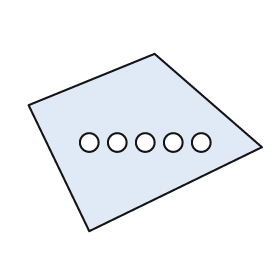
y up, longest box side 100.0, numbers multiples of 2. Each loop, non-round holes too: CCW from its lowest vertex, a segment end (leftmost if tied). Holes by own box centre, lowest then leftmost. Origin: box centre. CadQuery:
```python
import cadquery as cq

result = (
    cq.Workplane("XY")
    .moveTo(-24.0, -38.0)
    .lineTo(50.0, -2.0)
    .lineTo(4.0, 38.0)
    .lineTo(-50.0, 16.0)
    .close()
    .moveTo(-24.0, 0.0)
    .circle(4.0)
    .moveTo(-12.0, 0.0)
    .circle(4.0)
    .moveTo(0.0, 0.0)
    .circle(4.0)
    .moveTo(12.0, 0.0)
    .circle(4.0)
    .moveTo(24.0, 0.0)
    .circle(4.0)
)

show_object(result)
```